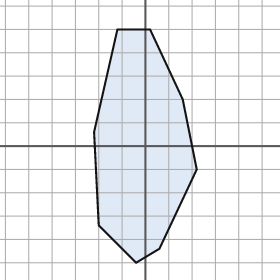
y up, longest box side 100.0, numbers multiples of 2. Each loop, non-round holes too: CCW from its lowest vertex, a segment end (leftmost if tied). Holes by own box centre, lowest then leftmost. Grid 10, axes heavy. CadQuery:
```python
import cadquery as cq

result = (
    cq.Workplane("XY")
    .moveTo(-4.0, -50.0)
    .lineTo(6.0, -44.0)
    .lineTo(22.0, -10.0)
    .lineTo(16.0, 20.0)
    .lineTo(2.0, 50.0)
    .lineTo(-12.0, 50.0)
    .lineTo(-22.0, 6.0)
    .lineTo(-20.0, -34.0)
    .close()
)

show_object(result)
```